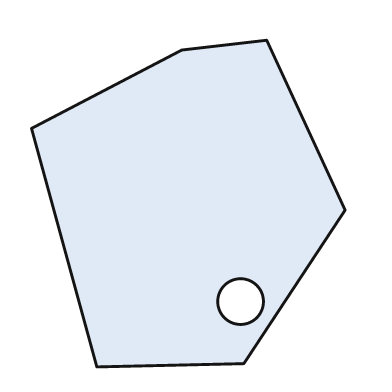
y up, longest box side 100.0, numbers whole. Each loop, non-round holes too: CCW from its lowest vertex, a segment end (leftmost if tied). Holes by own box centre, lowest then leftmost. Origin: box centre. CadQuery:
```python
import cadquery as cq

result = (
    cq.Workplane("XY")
    .moveTo(-28.0, -50.0)
    .lineTo(17.0, -49.0)
    .lineTo(48.0, -2.0)
    .lineTo(24.0, 50.0)
    .lineTo(-2.0, 47.0)
    .lineTo(-48.0, 23.0)
    .close()
    .moveTo(16.0, -30.0)
    .circle(7.0)
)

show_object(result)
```